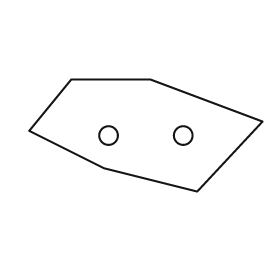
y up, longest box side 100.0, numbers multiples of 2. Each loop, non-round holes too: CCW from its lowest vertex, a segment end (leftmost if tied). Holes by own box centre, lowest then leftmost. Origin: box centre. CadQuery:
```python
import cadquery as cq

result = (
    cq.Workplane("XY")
    .moveTo(22.0, -24.0)
    .lineTo(50.0, 6.0)
    .lineTo(2.0, 24.0)
    .lineTo(-32.0, 24.0)
    .lineTo(-50.0, 2.0)
    .lineTo(-18.0, -14.0)
    .close()
    .moveTo(-16.0, 0.0)
    .circle(4.0)
    .moveTo(16.0, 0.0)
    .circle(4.0)
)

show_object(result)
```